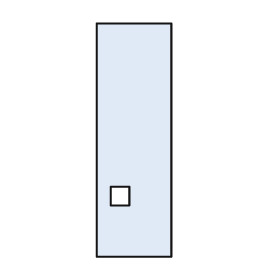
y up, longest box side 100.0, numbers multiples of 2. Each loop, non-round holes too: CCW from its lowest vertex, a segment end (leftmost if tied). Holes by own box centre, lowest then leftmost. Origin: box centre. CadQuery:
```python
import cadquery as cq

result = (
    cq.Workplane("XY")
    .moveTo(-16.0, -50.0)
    .lineTo(16.0, -50.0)
    .lineTo(16.0, 50.0)
    .lineTo(-16.0, 50.0)
    .close()
    .moveTo(-10.0, -28.0)
    .lineTo(-2.0, -28.0)
    .lineTo(-2.0, -20.0)
    .lineTo(-10.0, -20.0)
    .close()
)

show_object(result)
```